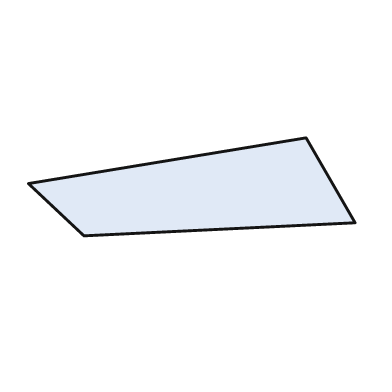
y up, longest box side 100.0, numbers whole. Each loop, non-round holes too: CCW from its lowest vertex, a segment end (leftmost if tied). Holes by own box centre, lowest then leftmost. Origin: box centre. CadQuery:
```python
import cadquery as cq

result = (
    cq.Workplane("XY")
    .moveTo(-33.0, -15.0)
    .lineTo(50.0, -11.0)
    .lineTo(35.0, 15.0)
    .lineTo(-50.0, 1.0)
    .close()
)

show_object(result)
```